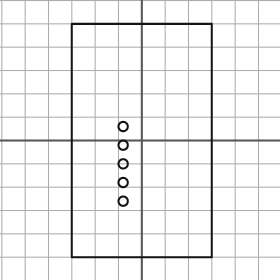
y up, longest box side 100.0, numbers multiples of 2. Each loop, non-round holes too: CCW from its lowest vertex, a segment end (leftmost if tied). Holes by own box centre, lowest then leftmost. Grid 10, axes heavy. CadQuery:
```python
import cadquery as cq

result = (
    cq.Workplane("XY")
    .moveTo(-30.0, -50.0)
    .lineTo(30.0, -50.0)
    .lineTo(30.0, 50.0)
    .lineTo(-30.0, 50.0)
    .close()
    .moveTo(-8.0, -26.0)
    .circle(2.0)
    .moveTo(-8.0, -18.0)
    .circle(2.0)
    .moveTo(-8.0, -10.0)
    .circle(2.0)
    .moveTo(-8.0, -2.0)
    .circle(2.0)
    .moveTo(-8.0, 6.0)
    .circle(2.0)
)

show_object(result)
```